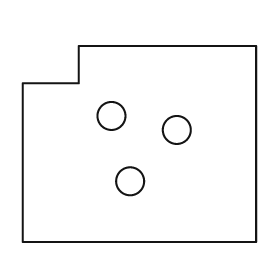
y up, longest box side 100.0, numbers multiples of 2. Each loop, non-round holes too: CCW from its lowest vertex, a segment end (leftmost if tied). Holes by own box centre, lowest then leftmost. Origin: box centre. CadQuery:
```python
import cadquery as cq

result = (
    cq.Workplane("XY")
    .moveTo(-50.0, -42.0)
    .lineTo(50.0, -42.0)
    .lineTo(50.0, 42.0)
    .lineTo(-26.0, 42.0)
    .lineTo(-26.0, 26.0)
    .lineTo(-50.0, 26.0)
    .close()
    .moveTo(-4.0, -16.0)
    .circle(6.0)
    .moveTo(16.0, 6.0)
    .circle(6.0)
    .moveTo(-12.0, 12.0)
    .circle(6.0)
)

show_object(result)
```